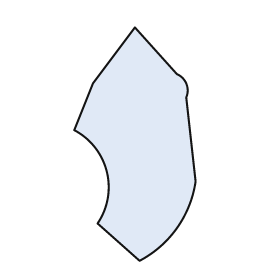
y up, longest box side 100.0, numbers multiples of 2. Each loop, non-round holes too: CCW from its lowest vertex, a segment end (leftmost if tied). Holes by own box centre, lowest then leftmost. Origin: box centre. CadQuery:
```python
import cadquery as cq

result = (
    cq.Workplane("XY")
    .moveTo(2.0, -50.0)
    .threePointArc((18.0, -36.0), (26.0, -16.0))
    .lineTo(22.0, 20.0)
    .threePointArc((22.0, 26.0), (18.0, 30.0))
    .lineTo(0.0, 50.0)
    .lineTo(-18.0, 26.0)
    .lineTo(-26.0, 6.0)
    .threePointArc((-12.0, -12.0), (-16.0, -34.0))
    .close()
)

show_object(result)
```